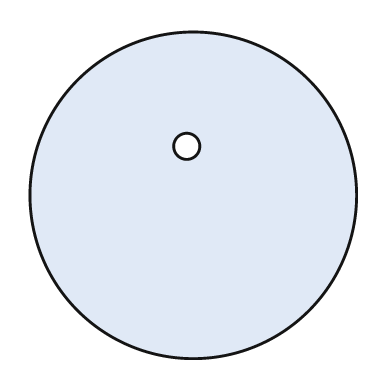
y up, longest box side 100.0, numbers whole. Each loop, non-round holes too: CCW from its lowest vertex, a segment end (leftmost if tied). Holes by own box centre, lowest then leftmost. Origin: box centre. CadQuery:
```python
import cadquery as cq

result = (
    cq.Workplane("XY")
    .moveTo(0.0, 0.0)
    .circle(50.0)
    .moveTo(-2.0, 15.0)
    .circle(4.0)
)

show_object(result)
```